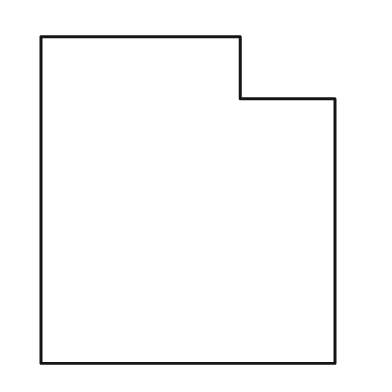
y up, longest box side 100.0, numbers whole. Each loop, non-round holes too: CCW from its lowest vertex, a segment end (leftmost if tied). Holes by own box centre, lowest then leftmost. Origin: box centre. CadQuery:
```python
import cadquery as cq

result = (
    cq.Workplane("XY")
    .moveTo(-45.0, -50.0)
    .lineTo(45.0, -50.0)
    .lineTo(45.0, 31.0)
    .lineTo(16.0, 31.0)
    .lineTo(16.0, 50.0)
    .lineTo(-45.0, 50.0)
    .close()
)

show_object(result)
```